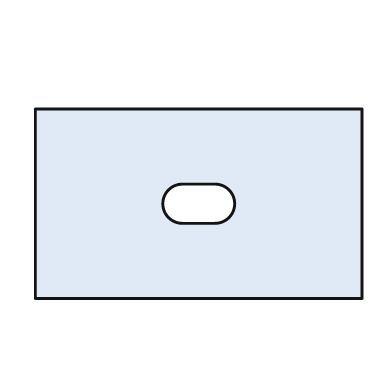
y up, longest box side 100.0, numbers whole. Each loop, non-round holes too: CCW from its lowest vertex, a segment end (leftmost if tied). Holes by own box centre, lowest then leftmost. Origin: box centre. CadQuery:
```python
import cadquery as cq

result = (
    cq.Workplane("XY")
    .moveTo(-50.0, -29.0)
    .lineTo(50.0, -29.0)
    .lineTo(50.0, 29.0)
    .lineTo(-50.0, 29.0)
    .close()
    .moveTo(-5.0, -6.0)
    .lineTo(5.0, -6.0)
    .threePointArc((11.0, 0.0), (5.0, 6.0))
    .lineTo(-5.0, 6.0)
    .threePointArc((-11.0, 0.0), (-5.0, -6.0))
    .close()
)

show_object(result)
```